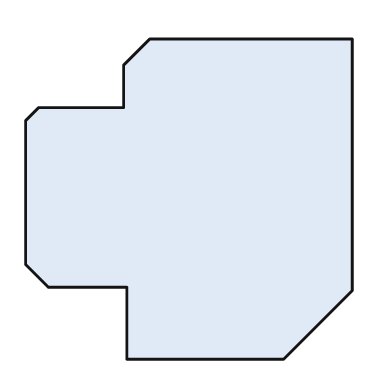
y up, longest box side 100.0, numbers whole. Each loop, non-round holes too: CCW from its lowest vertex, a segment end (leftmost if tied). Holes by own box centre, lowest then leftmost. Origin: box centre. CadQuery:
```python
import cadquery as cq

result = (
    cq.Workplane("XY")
    .moveTo(-19.0, -49.0)
    .lineTo(29.0, -49.0)
    .lineTo(50.0, -28.0)
    .lineTo(50.0, 49.0)
    .lineTo(-12.0, 49.0)
    .lineTo(-20.0, 41.0)
    .lineTo(-20.0, 28.0)
    .lineTo(-46.0, 28.0)
    .lineTo(-50.0, 24.0)
    .lineTo(-50.0, -20.0)
    .lineTo(-43.0, -27.0)
    .lineTo(-19.0, -27.0)
    .close()
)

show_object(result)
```